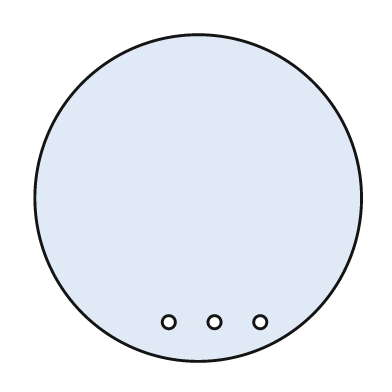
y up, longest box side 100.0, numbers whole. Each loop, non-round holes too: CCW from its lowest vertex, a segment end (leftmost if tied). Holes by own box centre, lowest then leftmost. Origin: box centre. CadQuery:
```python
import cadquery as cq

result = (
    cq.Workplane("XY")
    .moveTo(0.0, 0.0)
    .circle(50.0)
    .moveTo(-9.0, -38.0)
    .circle(2.0)
    .moveTo(5.0, -38.0)
    .circle(2.0)
    .moveTo(19.0, -38.0)
    .circle(2.0)
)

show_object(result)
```